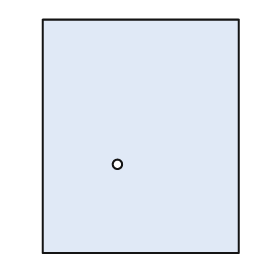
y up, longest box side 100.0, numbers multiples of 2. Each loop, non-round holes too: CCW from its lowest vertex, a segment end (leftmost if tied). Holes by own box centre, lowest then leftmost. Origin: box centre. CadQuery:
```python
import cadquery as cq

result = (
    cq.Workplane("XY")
    .moveTo(-42.0, -50.0)
    .lineTo(42.0, -50.0)
    .lineTo(42.0, 50.0)
    .lineTo(-42.0, 50.0)
    .close()
    .moveTo(-10.0, -12.0)
    .circle(2.0)
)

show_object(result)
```